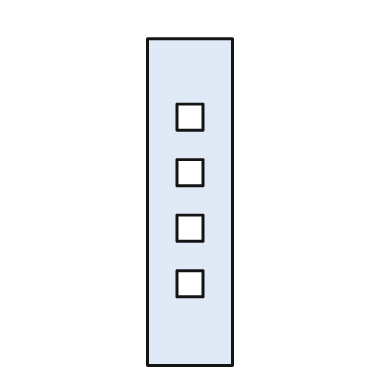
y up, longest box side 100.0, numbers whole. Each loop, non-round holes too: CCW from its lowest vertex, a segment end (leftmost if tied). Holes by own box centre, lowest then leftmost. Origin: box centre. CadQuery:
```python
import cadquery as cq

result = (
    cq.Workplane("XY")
    .moveTo(-13.0, -50.0)
    .lineTo(13.0, -50.0)
    .lineTo(13.0, 50.0)
    .lineTo(-13.0, 50.0)
    .close()
    .moveTo(-4.0, -29.0)
    .lineTo(4.0, -29.0)
    .lineTo(4.0, -21.0)
    .lineTo(-4.0, -21.0)
    .close()
    .moveTo(-4.0, -12.0)
    .lineTo(4.0, -12.0)
    .lineTo(4.0, -4.0)
    .lineTo(-4.0, -4.0)
    .close()
    .moveTo(-4.0, 5.0)
    .lineTo(4.0, 5.0)
    .lineTo(4.0, 13.0)
    .lineTo(-4.0, 13.0)
    .close()
    .moveTo(-4.0, 22.0)
    .lineTo(4.0, 22.0)
    .lineTo(4.0, 30.0)
    .lineTo(-4.0, 30.0)
    .close()
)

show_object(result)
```